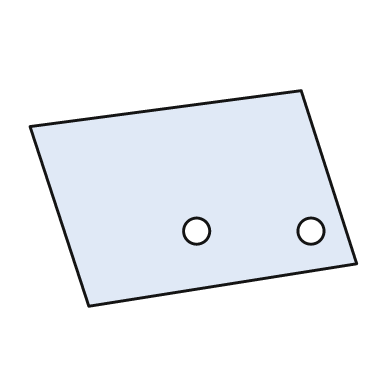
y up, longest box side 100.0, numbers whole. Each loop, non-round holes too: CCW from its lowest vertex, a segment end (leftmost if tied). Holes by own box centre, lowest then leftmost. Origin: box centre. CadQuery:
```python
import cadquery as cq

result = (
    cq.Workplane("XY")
    .moveTo(-32.0, -33.0)
    .lineTo(50.0, -20.0)
    .lineTo(33.0, 33.0)
    .lineTo(-50.0, 22.0)
    .close()
    .moveTo(1.0, -10.0)
    .circle(4.0)
    .moveTo(36.0, -10.0)
    .circle(4.0)
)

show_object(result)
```